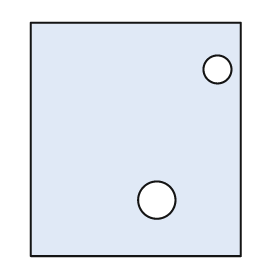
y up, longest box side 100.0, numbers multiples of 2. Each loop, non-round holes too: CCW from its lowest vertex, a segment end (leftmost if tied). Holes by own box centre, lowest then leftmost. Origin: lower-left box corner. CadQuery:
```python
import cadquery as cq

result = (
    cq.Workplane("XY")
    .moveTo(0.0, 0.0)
    .lineTo(90.0, 0.0)
    .lineTo(90.0, 100.0)
    .lineTo(0.0, 100.0)
    .close()
    .moveTo(54.0, 24.0)
    .circle(8.0)
    .moveTo(80.0, 80.0)
    .circle(6.0)
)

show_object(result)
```